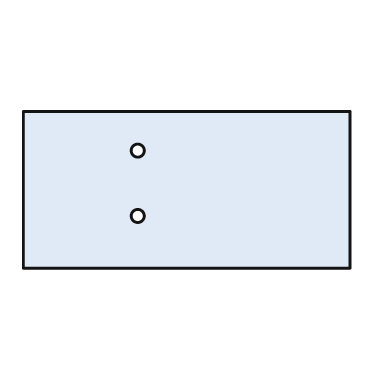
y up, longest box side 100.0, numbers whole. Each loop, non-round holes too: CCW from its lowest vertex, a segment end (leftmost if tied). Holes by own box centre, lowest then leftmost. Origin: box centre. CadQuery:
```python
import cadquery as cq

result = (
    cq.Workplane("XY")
    .moveTo(-50.0, -24.0)
    .lineTo(50.0, -24.0)
    .lineTo(50.0, 24.0)
    .lineTo(-50.0, 24.0)
    .close()
    .moveTo(-15.0, -8.0)
    .circle(2.0)
    .moveTo(-15.0, 12.0)
    .circle(2.0)
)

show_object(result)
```